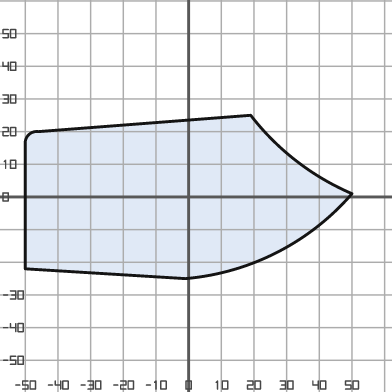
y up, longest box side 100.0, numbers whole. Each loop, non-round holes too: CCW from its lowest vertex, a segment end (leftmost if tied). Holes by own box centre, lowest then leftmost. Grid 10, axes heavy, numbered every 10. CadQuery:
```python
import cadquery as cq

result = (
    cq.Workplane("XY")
    .moveTo(-1.0, -25.0)
    .threePointArc((27.0, -17.0), (50.0, 1.0))
    .threePointArc((33.0, 11.0), (19.0, 25.0))
    .lineTo(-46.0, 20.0)
    .threePointArc((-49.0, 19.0), (-50.0, 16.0))
    .lineTo(-50.0, -22.0)
    .close()
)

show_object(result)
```